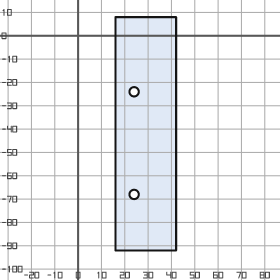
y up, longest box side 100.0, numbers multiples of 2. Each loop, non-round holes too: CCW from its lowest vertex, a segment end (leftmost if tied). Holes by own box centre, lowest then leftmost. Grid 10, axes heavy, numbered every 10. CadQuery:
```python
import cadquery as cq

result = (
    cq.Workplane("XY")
    .moveTo(16.0, -92.0)
    .lineTo(42.0, -92.0)
    .lineTo(42.0, 8.0)
    .lineTo(16.0, 8.0)
    .close()
    .moveTo(24.0, -68.0)
    .circle(2.0)
    .moveTo(24.0, -24.0)
    .circle(2.0)
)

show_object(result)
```